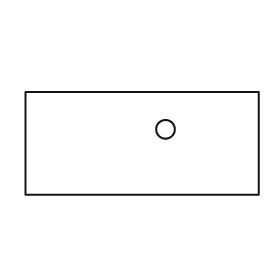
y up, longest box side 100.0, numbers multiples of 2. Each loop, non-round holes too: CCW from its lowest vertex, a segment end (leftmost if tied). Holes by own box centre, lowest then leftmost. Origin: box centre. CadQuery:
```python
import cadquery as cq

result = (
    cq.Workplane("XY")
    .moveTo(-50.0, -22.0)
    .lineTo(50.0, -22.0)
    .lineTo(50.0, 22.0)
    .lineTo(-50.0, 22.0)
    .close()
    .moveTo(10.0, 6.0)
    .circle(4.0)
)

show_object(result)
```